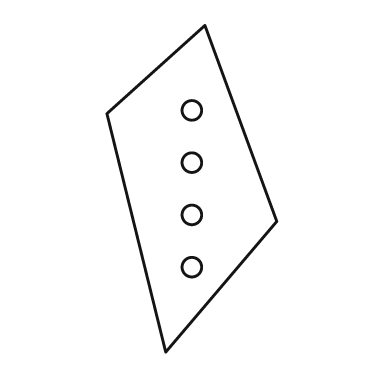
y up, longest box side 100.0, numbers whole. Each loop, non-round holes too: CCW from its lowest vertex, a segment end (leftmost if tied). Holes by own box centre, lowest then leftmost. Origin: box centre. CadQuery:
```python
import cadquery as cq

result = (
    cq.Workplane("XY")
    .moveTo(-8.0, -50.0)
    .lineTo(26.0, -10.0)
    .lineTo(4.0, 50.0)
    .lineTo(-26.0, 23.0)
    .close()
    .moveTo(0.0, -24.0)
    .circle(3.0)
    .moveTo(0.0, -8.0)
    .circle(3.0)
    .moveTo(0.0, 8.0)
    .circle(3.0)
    .moveTo(0.0, 24.0)
    .circle(3.0)
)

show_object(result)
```